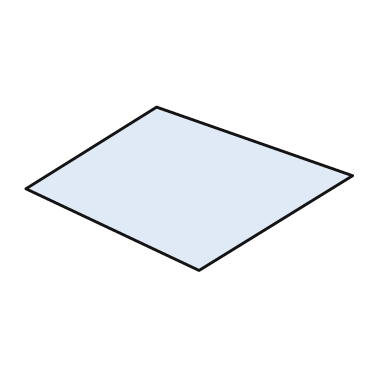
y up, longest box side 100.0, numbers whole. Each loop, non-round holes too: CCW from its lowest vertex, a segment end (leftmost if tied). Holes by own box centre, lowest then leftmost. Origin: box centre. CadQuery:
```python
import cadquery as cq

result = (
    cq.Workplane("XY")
    .moveTo(3.0, -25.0)
    .lineTo(50.0, 4.0)
    .lineTo(-10.0, 25.0)
    .lineTo(-50.0, 0.0)
    .close()
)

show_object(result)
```